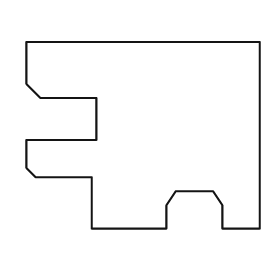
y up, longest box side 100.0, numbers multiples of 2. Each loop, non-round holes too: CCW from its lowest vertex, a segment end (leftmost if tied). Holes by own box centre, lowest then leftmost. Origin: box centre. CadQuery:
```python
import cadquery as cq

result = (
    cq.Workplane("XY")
    .moveTo(-22.0, -40.0)
    .lineTo(10.0, -40.0)
    .lineTo(10.0, -30.0)
    .lineTo(14.0, -24.0)
    .lineTo(30.0, -24.0)
    .lineTo(34.0, -30.0)
    .lineTo(34.0, -40.0)
    .lineTo(50.0, -40.0)
    .lineTo(50.0, 40.0)
    .lineTo(-50.0, 40.0)
    .lineTo(-50.0, 22.0)
    .lineTo(-44.0, 16.0)
    .lineTo(-20.0, 16.0)
    .lineTo(-20.0, -2.0)
    .lineTo(-50.0, -2.0)
    .lineTo(-50.0, -14.0)
    .lineTo(-46.0, -18.0)
    .lineTo(-22.0, -18.0)
    .close()
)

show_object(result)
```